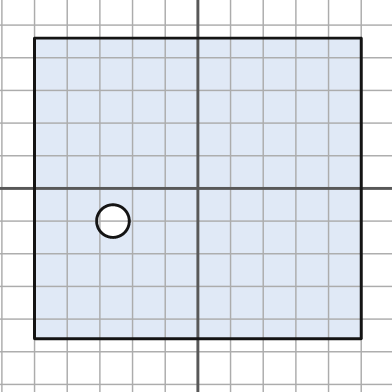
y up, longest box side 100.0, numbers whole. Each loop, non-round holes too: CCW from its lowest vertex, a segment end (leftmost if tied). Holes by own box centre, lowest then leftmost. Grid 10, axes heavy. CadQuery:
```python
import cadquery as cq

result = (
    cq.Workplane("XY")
    .moveTo(-50.0, -46.0)
    .lineTo(50.0, -46.0)
    .lineTo(50.0, 46.0)
    .lineTo(-50.0, 46.0)
    .close()
    .moveTo(-26.0, -10.0)
    .circle(5.0)
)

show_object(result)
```